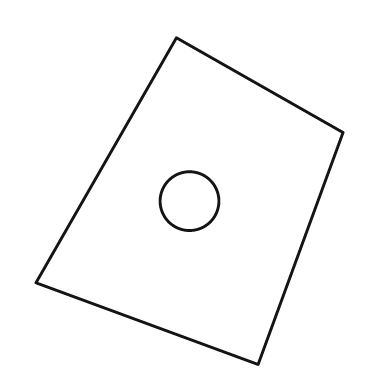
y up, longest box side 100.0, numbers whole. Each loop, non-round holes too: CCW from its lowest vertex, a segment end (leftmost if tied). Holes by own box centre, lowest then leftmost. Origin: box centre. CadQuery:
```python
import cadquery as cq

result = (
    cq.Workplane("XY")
    .moveTo(21.0, -50.0)
    .lineTo(47.0, 21.0)
    .lineTo(-4.0, 50.0)
    .lineTo(-47.0, -25.0)
    .close()
    .moveTo(0.0, 0.0)
    .circle(9.0)
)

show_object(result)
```